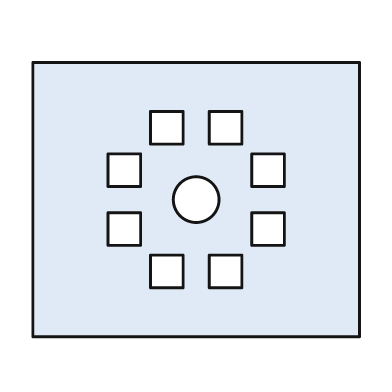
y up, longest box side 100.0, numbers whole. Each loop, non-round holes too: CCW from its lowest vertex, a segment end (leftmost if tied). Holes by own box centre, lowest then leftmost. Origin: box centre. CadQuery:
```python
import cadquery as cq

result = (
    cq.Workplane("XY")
    .moveTo(-50.0, -42.0)
    .lineTo(50.0, -42.0)
    .lineTo(50.0, 42.0)
    .lineTo(-50.0, 42.0)
    .close()
    .moveTo(-14.0, -27.0)
    .lineTo(-4.0, -27.0)
    .lineTo(-4.0, -17.0)
    .lineTo(-14.0, -17.0)
    .close()
    .moveTo(4.0, -27.0)
    .lineTo(14.0, -27.0)
    .lineTo(14.0, -17.0)
    .lineTo(4.0, -17.0)
    .close()
    .moveTo(-27.0, -14.0)
    .lineTo(-17.0, -14.0)
    .lineTo(-17.0, -4.0)
    .lineTo(-27.0, -4.0)
    .close()
    .moveTo(17.0, -14.0)
    .lineTo(27.0, -14.0)
    .lineTo(27.0, -4.0)
    .lineTo(17.0, -4.0)
    .close()
    .moveTo(0.0, 0.0)
    .circle(7.0)
    .moveTo(-27.0, 4.0)
    .lineTo(-17.0, 4.0)
    .lineTo(-17.0, 14.0)
    .lineTo(-27.0, 14.0)
    .close()
    .moveTo(17.0, 4.0)
    .lineTo(27.0, 4.0)
    .lineTo(27.0, 14.0)
    .lineTo(17.0, 14.0)
    .close()
    .moveTo(-14.0, 17.0)
    .lineTo(-4.0, 17.0)
    .lineTo(-4.0, 27.0)
    .lineTo(-14.0, 27.0)
    .close()
    .moveTo(4.0, 17.0)
    .lineTo(14.0, 17.0)
    .lineTo(14.0, 27.0)
    .lineTo(4.0, 27.0)
    .close()
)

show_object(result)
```